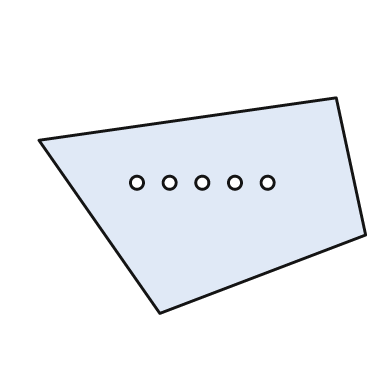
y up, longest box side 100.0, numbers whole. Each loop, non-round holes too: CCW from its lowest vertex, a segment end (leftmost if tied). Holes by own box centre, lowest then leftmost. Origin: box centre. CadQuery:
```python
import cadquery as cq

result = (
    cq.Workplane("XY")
    .moveTo(-13.0, -33.0)
    .lineTo(50.0, -9.0)
    .lineTo(41.0, 33.0)
    .lineTo(-50.0, 20.0)
    .close()
    .moveTo(-20.0, 7.0)
    .circle(2.0)
    .moveTo(-10.0, 7.0)
    .circle(2.0)
    .moveTo(0.0, 7.0)
    .circle(2.0)
    .moveTo(10.0, 7.0)
    .circle(2.0)
    .moveTo(20.0, 7.0)
    .circle(2.0)
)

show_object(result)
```